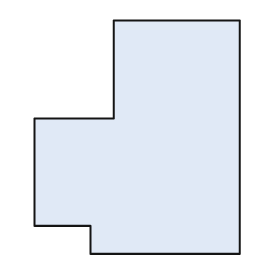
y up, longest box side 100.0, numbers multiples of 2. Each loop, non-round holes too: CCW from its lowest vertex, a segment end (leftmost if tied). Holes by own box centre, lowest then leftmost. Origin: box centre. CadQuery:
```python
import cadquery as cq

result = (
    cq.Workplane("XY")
    .moveTo(-20.0, -50.0)
    .lineTo(44.0, -50.0)
    .lineTo(44.0, 50.0)
    .lineTo(-10.0, 50.0)
    .lineTo(-10.0, 8.0)
    .lineTo(-44.0, 8.0)
    .lineTo(-44.0, -38.0)
    .lineTo(-20.0, -38.0)
    .close()
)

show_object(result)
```